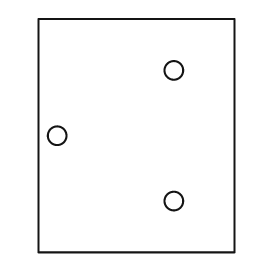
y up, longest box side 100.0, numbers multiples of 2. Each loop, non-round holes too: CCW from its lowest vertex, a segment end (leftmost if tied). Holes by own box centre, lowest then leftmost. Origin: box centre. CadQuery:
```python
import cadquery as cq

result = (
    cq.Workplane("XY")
    .moveTo(-42.0, -50.0)
    .lineTo(42.0, -50.0)
    .lineTo(42.0, 50.0)
    .lineTo(-42.0, 50.0)
    .close()
    .moveTo(16.0, -28.0)
    .circle(4.0)
    .moveTo(-34.0, 0.0)
    .circle(4.0)
    .moveTo(16.0, 28.0)
    .circle(4.0)
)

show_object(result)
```